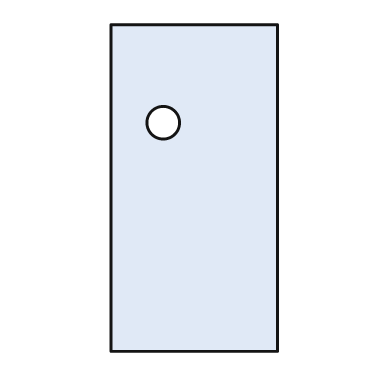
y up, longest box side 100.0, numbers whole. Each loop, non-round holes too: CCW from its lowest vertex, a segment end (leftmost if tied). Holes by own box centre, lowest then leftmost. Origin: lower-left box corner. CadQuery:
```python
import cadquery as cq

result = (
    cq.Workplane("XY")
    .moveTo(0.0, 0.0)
    .lineTo(51.0, 0.0)
    .lineTo(51.0, 100.0)
    .lineTo(0.0, 100.0)
    .close()
    .moveTo(16.0, 70.0)
    .circle(5.0)
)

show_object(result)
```